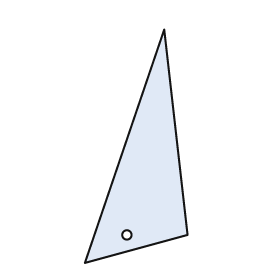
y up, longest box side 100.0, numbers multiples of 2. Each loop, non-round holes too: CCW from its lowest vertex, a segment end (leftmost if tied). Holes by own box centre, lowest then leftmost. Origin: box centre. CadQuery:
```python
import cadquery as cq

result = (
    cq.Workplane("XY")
    .moveTo(-22.0, -50.0)
    .lineTo(22.0, -38.0)
    .lineTo(12.0, 50.0)
    .close()
    .moveTo(-4.0, -38.0)
    .circle(2.0)
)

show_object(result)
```